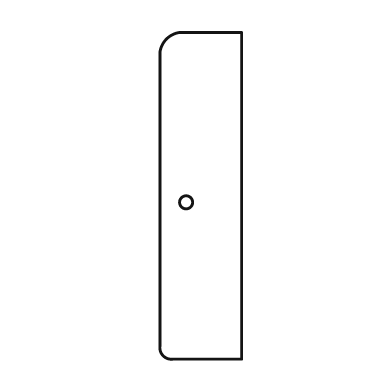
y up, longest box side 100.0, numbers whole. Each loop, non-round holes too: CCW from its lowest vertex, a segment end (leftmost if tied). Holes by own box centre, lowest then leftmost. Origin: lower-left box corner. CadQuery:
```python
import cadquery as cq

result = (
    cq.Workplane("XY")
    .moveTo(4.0, 0.0)
    .lineTo(25.0, 0.0)
    .lineTo(25.0, 100.0)
    .lineTo(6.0, 100.0)
    .threePointArc((2.0, 98.0), (0.0, 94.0))
    .lineTo(0.0, 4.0)
    .threePointArc((1.0, 1.0), (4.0, 0.0))
    .close()
    .moveTo(8.0, 48.0)
    .circle(2.0)
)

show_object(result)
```